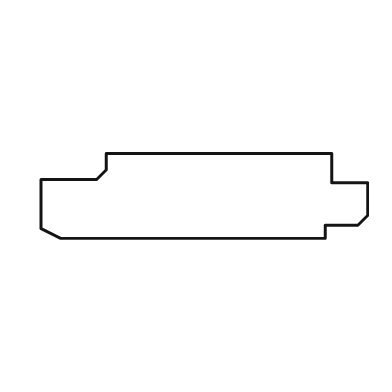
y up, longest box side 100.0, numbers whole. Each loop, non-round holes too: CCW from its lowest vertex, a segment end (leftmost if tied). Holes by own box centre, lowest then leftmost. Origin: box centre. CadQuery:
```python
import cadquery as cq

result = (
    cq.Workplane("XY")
    .moveTo(-44.0, -13.0)
    .lineTo(37.0, -13.0)
    .lineTo(37.0, -9.0)
    .lineTo(47.0, -9.0)
    .lineTo(50.0, -6.0)
    .lineTo(50.0, 4.0)
    .lineTo(39.0, 4.0)
    .lineTo(39.0, 13.0)
    .lineTo(-30.0, 13.0)
    .lineTo(-30.0, 8.0)
    .lineTo(-33.0, 5.0)
    .lineTo(-50.0, 5.0)
    .lineTo(-50.0, -10.0)
    .close()
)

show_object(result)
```